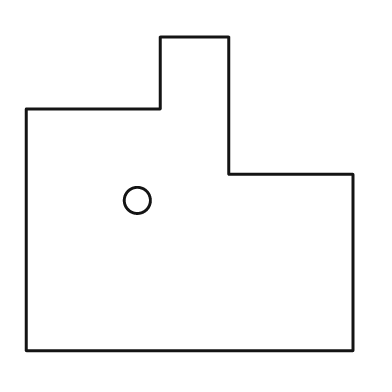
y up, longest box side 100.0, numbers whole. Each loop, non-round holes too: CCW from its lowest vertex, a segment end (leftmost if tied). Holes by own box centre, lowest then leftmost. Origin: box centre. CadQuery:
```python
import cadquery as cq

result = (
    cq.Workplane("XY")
    .moveTo(-50.0, -48.0)
    .lineTo(50.0, -48.0)
    .lineTo(50.0, 6.0)
    .lineTo(12.0, 6.0)
    .lineTo(12.0, 48.0)
    .lineTo(-9.0, 48.0)
    .lineTo(-9.0, 26.0)
    .lineTo(-50.0, 26.0)
    .close()
    .moveTo(-16.0, -2.0)
    .circle(4.0)
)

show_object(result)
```